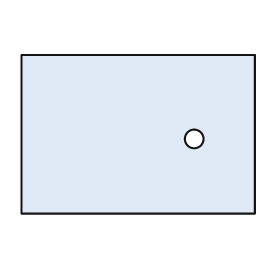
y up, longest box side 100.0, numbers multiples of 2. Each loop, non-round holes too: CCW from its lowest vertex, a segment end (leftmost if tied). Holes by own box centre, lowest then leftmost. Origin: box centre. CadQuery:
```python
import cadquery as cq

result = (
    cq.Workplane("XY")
    .moveTo(-50.0, -34.0)
    .lineTo(50.0, -34.0)
    .lineTo(50.0, 34.0)
    .lineTo(-50.0, 34.0)
    .close()
    .moveTo(24.0, -2.0)
    .circle(4.0)
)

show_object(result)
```